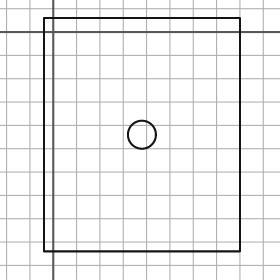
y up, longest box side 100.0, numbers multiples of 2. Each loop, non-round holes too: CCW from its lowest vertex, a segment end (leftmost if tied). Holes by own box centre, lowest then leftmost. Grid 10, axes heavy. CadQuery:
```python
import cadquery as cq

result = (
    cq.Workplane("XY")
    .moveTo(-4.0, -94.0)
    .lineTo(80.0, -94.0)
    .lineTo(80.0, 6.0)
    .lineTo(-4.0, 6.0)
    .close()
    .moveTo(38.0, -44.0)
    .circle(6.0)
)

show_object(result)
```